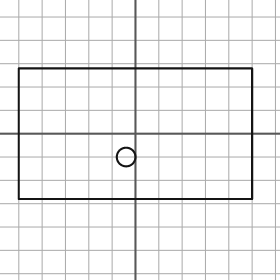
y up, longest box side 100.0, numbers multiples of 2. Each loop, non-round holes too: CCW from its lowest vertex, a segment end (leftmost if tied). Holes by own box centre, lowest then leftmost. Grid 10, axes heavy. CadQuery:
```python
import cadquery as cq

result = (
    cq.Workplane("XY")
    .moveTo(-50.0, -28.0)
    .lineTo(50.0, -28.0)
    .lineTo(50.0, 28.0)
    .lineTo(-50.0, 28.0)
    .close()
    .moveTo(-4.0, -10.0)
    .circle(4.0)
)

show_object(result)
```